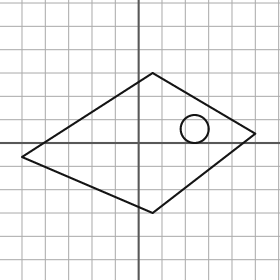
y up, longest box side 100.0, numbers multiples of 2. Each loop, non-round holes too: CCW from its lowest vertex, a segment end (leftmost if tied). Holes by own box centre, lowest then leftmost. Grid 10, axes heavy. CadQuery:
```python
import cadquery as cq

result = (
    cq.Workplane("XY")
    .moveTo(6.0, -30.0)
    .lineTo(50.0, 4.0)
    .lineTo(6.0, 30.0)
    .lineTo(-50.0, -6.0)
    .close()
    .moveTo(24.0, 6.0)
    .circle(6.0)
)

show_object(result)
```